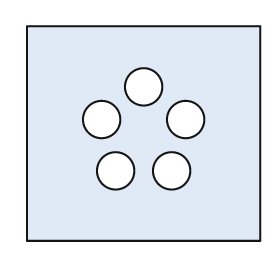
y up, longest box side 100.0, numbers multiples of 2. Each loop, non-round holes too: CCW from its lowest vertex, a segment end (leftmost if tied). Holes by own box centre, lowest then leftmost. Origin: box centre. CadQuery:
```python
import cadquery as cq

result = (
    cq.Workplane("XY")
    .moveTo(-50.0, -46.0)
    .lineTo(50.0, -46.0)
    .lineTo(50.0, 46.0)
    .lineTo(-50.0, 46.0)
    .close()
    .moveTo(-12.0, -16.0)
    .circle(8.0)
    .moveTo(12.0, -16.0)
    .circle(8.0)
    .moveTo(-18.0, 6.0)
    .circle(8.0)
    .moveTo(18.0, 6.0)
    .circle(8.0)
    .moveTo(0.0, 20.0)
    .circle(8.0)
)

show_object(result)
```